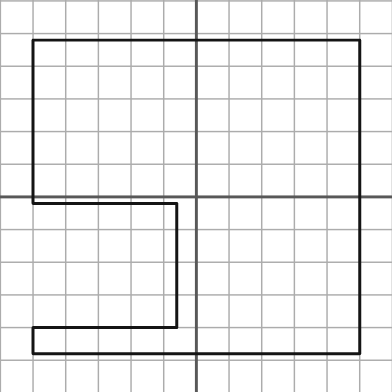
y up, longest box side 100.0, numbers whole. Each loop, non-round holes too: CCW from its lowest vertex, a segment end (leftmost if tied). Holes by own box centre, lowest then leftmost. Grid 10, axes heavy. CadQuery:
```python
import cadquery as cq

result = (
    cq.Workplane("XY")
    .moveTo(-50.0, -48.0)
    .lineTo(50.0, -48.0)
    .lineTo(50.0, 48.0)
    .lineTo(-50.0, 48.0)
    .lineTo(-50.0, -2.0)
    .lineTo(-6.0, -2.0)
    .lineTo(-6.0, -40.0)
    .lineTo(-50.0, -40.0)
    .close()
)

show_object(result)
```